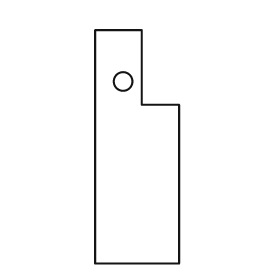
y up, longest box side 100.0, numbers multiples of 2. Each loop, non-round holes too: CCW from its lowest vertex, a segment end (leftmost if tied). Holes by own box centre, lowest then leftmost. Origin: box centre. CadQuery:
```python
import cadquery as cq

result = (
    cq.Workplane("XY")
    .moveTo(-18.0, -50.0)
    .lineTo(18.0, -50.0)
    .lineTo(18.0, 18.0)
    .lineTo(2.0, 18.0)
    .lineTo(2.0, 50.0)
    .lineTo(-18.0, 50.0)
    .close()
    .moveTo(-6.0, 28.0)
    .circle(4.0)
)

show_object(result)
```